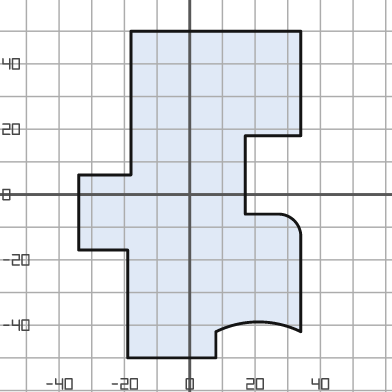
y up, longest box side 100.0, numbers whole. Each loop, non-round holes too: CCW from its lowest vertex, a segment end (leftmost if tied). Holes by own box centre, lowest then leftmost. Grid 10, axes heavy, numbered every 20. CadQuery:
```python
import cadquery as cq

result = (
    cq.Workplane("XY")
    .moveTo(-19.0, -50.0)
    .lineTo(8.0, -50.0)
    .lineTo(8.0, -42.0)
    .threePointArc((21.0, -39.0), (34.0, -42.0))
    .lineTo(34.0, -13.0)
    .threePointArc((32.0, -8.0), (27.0, -6.0))
    .lineTo(17.0, -6.0)
    .lineTo(17.0, 18.0)
    .lineTo(34.0, 18.0)
    .lineTo(34.0, 50.0)
    .lineTo(-18.0, 50.0)
    .lineTo(-18.0, 6.0)
    .lineTo(-34.0, 6.0)
    .lineTo(-34.0, -17.0)
    .lineTo(-19.0, -17.0)
    .close()
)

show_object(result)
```